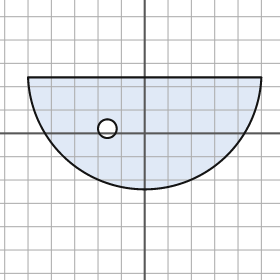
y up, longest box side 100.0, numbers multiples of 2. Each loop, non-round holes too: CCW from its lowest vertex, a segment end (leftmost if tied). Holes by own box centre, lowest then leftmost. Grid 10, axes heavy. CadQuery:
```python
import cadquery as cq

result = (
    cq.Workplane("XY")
    .moveTo(-50.0, 24.0)
    .threePointArc((0.0, -24.0), (50.0, 24.0))
    .close()
    .moveTo(-16.0, 2.0)
    .circle(4.0)
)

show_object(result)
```